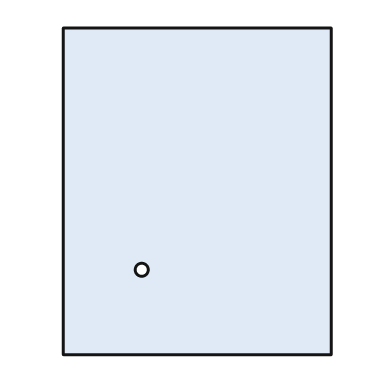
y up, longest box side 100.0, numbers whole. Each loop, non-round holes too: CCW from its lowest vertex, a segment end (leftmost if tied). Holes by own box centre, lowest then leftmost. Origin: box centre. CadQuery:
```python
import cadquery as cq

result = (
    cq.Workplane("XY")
    .moveTo(-41.0, -50.0)
    .lineTo(41.0, -50.0)
    .lineTo(41.0, 50.0)
    .lineTo(-41.0, 50.0)
    .close()
    .moveTo(-17.0, -24.0)
    .circle(2.0)
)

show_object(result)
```